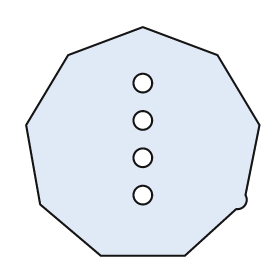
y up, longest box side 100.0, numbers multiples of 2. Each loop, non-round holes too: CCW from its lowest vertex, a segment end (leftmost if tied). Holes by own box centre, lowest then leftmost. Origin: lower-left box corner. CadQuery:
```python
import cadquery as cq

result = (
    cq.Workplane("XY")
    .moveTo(32.0, 0.0)
    .lineTo(68.0, 0.0)
    .lineTo(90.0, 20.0)
    .threePointArc((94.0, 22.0), (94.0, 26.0))
    .lineTo(100.0, 56.0)
    .lineTo(82.0, 86.0)
    .lineTo(50.0, 98.0)
    .lineTo(18.0, 86.0)
    .lineTo(0.0, 56.0)
    .lineTo(6.0, 22.0)
    .close()
    .moveTo(50.0, 26.0)
    .circle(4.0)
    .moveTo(50.0, 42.0)
    .circle(4.0)
    .moveTo(50.0, 58.0)
    .circle(4.0)
    .moveTo(50.0, 74.0)
    .circle(4.0)
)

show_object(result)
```